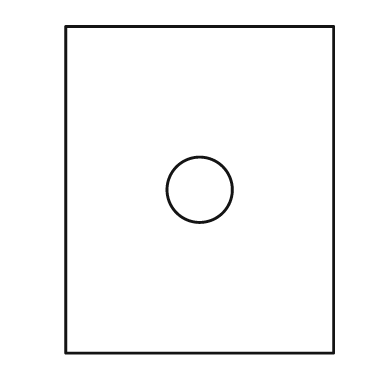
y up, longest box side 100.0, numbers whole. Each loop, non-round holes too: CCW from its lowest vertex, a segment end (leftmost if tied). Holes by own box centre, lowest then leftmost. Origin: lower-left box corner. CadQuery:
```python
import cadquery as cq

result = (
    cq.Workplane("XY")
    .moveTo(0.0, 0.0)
    .lineTo(82.0, 0.0)
    .lineTo(82.0, 100.0)
    .lineTo(0.0, 100.0)
    .close()
    .moveTo(41.0, 50.0)
    .circle(10.0)
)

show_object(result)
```